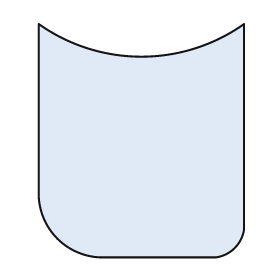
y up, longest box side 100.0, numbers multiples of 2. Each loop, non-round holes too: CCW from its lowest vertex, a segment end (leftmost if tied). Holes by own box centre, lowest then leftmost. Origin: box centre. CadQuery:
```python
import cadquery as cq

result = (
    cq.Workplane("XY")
    .moveTo(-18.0, -50.0)
    .lineTo(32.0, -50.0)
    .threePointArc((40.0, -46.0), (44.0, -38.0))
    .lineTo(44.0, 50.0)
    .threePointArc((0.0, 36.0), (-44.0, 50.0))
    .lineTo(-44.0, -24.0)
    .threePointArc((-36.0, -42.0), (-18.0, -50.0))
    .close()
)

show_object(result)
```